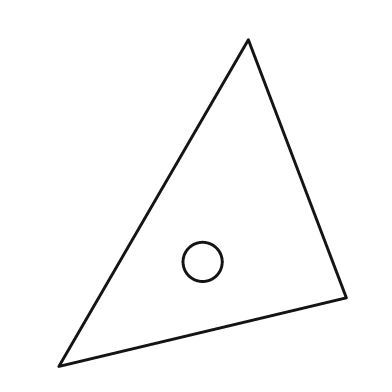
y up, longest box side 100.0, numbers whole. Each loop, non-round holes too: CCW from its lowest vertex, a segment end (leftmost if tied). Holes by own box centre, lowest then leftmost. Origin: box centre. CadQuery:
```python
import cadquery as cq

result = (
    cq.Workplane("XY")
    .moveTo(-44.0, -50.0)
    .lineTo(44.0, -29.0)
    .lineTo(14.0, 50.0)
    .close()
    .moveTo(0.0, -18.0)
    .circle(6.0)
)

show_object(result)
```